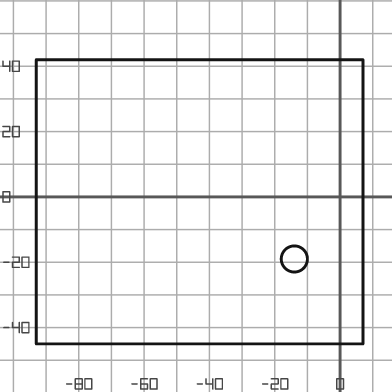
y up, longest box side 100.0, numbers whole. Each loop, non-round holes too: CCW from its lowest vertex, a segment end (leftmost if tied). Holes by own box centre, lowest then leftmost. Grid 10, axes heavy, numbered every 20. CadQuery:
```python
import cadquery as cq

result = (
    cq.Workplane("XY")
    .moveTo(-93.0, -45.0)
    .lineTo(7.0, -45.0)
    .lineTo(7.0, 42.0)
    .lineTo(-93.0, 42.0)
    .close()
    .moveTo(-14.0, -19.0)
    .circle(4.0)
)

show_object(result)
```